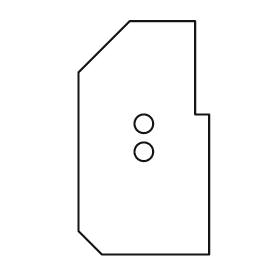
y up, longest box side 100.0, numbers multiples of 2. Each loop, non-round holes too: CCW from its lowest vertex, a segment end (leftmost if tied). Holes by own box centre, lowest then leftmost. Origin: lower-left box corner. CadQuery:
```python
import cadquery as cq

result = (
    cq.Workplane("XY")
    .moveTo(10.0, 0.0)
    .lineTo(56.0, 0.0)
    .lineTo(56.0, 60.0)
    .lineTo(50.0, 60.0)
    .lineTo(50.0, 100.0)
    .lineTo(22.0, 100.0)
    .lineTo(0.0, 78.0)
    .lineTo(0.0, 10.0)
    .close()
    .moveTo(28.0, 44.0)
    .circle(4.0)
    .moveTo(28.0, 56.0)
    .circle(4.0)
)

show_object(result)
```